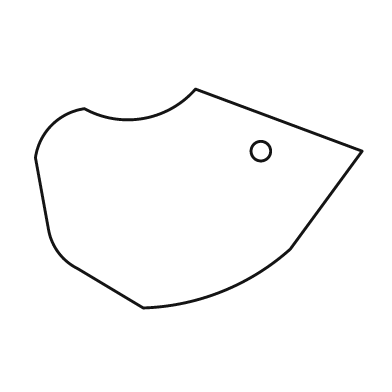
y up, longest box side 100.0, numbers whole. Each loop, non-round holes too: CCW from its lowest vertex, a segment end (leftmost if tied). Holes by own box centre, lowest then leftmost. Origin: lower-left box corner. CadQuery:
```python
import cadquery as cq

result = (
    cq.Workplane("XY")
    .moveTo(33.0, 0.0)
    .threePointArc((57.0, 5.0), (78.0, 18.0))
    .lineTo(100.0, 48.0)
    .lineTo(49.0, 67.0)
    .threePointArc((33.0, 58.0), (15.0, 61.0))
    .threePointArc((5.0, 56.0), (0.0, 46.0))
    .lineTo(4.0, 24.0)
    .threePointArc((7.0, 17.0), (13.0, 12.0))
    .close()
    .moveTo(69.0, 48.0)
    .circle(3.0)
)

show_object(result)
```